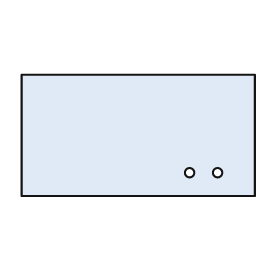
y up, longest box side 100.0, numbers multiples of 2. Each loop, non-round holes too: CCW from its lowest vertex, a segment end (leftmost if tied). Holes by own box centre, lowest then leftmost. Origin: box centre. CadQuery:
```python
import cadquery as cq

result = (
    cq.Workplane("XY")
    .moveTo(-50.0, -26.0)
    .lineTo(50.0, -26.0)
    .lineTo(50.0, 26.0)
    .lineTo(-50.0, 26.0)
    .close()
    .moveTo(22.0, -16.0)
    .circle(2.0)
    .moveTo(34.0, -16.0)
    .circle(2.0)
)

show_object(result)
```